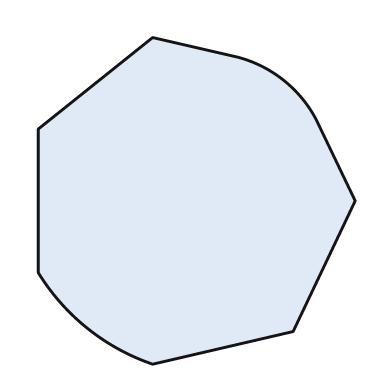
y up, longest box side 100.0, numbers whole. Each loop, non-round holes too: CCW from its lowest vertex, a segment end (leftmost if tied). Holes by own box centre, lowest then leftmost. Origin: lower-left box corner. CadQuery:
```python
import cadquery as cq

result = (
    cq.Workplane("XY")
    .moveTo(35.0, 0.0)
    .lineTo(78.0, 10.0)
    .lineTo(97.0, 50.0)
    .lineTo(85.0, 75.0)
    .threePointArc((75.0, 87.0), (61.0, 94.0))
    .lineTo(35.0, 100.0)
    .lineTo(0.0, 72.0)
    .lineTo(0.0, 28.0)
    .threePointArc((15.0, 11.0), (35.0, 0.0))
    .close()
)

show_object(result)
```